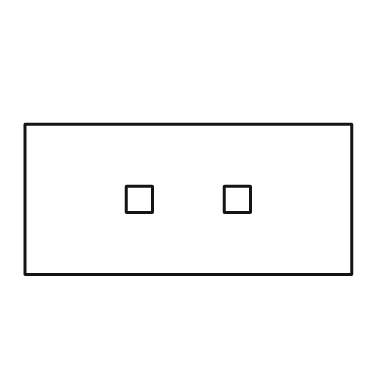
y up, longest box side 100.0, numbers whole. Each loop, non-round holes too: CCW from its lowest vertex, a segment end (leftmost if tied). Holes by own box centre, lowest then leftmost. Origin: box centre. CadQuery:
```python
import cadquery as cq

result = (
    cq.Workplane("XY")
    .moveTo(-50.0, -23.0)
    .lineTo(50.0, -23.0)
    .lineTo(50.0, 23.0)
    .lineTo(-50.0, 23.0)
    .close()
    .moveTo(-19.0, -4.0)
    .lineTo(-11.0, -4.0)
    .lineTo(-11.0, 4.0)
    .lineTo(-19.0, 4.0)
    .close()
    .moveTo(11.0, -4.0)
    .lineTo(19.0, -4.0)
    .lineTo(19.0, 4.0)
    .lineTo(11.0, 4.0)
    .close()
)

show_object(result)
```